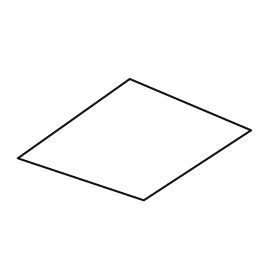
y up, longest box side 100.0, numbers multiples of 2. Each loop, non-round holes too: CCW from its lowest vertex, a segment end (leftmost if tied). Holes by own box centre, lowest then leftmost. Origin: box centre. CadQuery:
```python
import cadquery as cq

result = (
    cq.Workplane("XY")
    .moveTo(4.0, -26.0)
    .lineTo(50.0, 4.0)
    .lineTo(-2.0, 26.0)
    .lineTo(-50.0, -8.0)
    .close()
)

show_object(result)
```